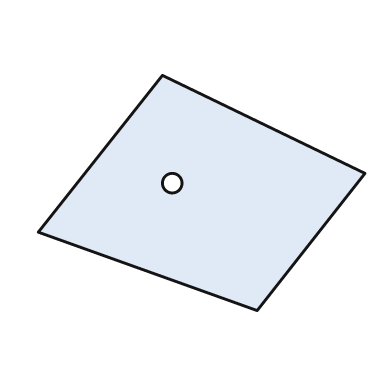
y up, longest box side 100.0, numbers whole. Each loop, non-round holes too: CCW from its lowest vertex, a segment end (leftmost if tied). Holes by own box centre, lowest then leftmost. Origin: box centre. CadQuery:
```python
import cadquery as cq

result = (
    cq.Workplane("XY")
    .moveTo(17.0, -36.0)
    .lineTo(50.0, 6.0)
    .lineTo(-12.0, 36.0)
    .lineTo(-50.0, -12.0)
    .close()
    .moveTo(-9.0, 3.0)
    .circle(3.0)
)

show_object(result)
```